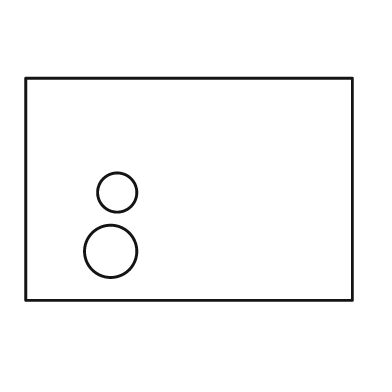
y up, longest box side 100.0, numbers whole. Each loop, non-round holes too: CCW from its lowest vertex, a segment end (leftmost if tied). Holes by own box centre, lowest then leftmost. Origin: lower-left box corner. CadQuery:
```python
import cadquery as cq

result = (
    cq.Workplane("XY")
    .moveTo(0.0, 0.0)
    .lineTo(100.0, 0.0)
    .lineTo(100.0, 68.0)
    .lineTo(0.0, 68.0)
    .close()
    .moveTo(26.0, 15.0)
    .circle(8.0)
    .moveTo(28.0, 33.0)
    .circle(6.0)
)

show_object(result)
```